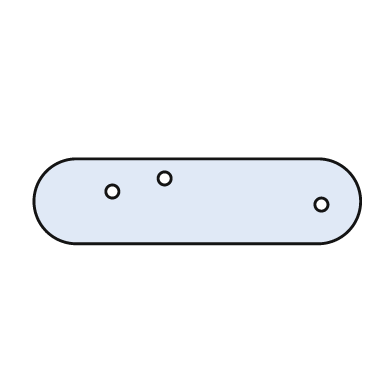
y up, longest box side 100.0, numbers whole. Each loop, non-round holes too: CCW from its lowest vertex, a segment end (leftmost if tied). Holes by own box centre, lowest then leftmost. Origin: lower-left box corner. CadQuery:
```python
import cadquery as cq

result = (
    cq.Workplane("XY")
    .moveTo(13.0, 0.0)
    .lineTo(87.0, 0.0)
    .threePointArc((100.0, 13.0), (87.0, 26.0))
    .lineTo(13.0, 26.0)
    .threePointArc((0.0, 13.0), (13.0, 0.0))
    .close()
    .moveTo(88.0, 12.0)
    .circle(2.0)
    .moveTo(24.0, 16.0)
    .circle(2.0)
    .moveTo(40.0, 20.0)
    .circle(2.0)
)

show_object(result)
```